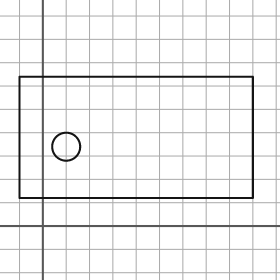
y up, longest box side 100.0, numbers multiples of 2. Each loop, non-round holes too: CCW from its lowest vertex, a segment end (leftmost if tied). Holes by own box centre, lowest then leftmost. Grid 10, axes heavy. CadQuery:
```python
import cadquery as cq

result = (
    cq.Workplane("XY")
    .moveTo(-10.0, 12.0)
    .lineTo(90.0, 12.0)
    .lineTo(90.0, 64.0)
    .lineTo(-10.0, 64.0)
    .close()
    .moveTo(10.0, 34.0)
    .circle(6.0)
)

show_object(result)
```